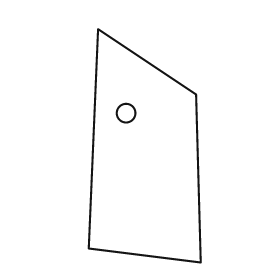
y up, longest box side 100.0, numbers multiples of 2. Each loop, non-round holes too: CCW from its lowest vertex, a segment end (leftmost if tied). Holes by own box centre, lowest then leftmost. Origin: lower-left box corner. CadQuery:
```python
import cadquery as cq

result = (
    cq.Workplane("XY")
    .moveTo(48.0, 0.0)
    .lineTo(46.0, 72.0)
    .lineTo(4.0, 100.0)
    .lineTo(0.0, 6.0)
    .close()
    .moveTo(16.0, 64.0)
    .circle(4.0)
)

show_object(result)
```